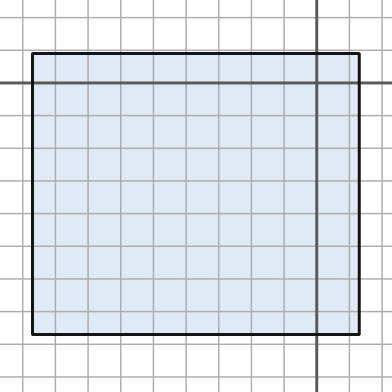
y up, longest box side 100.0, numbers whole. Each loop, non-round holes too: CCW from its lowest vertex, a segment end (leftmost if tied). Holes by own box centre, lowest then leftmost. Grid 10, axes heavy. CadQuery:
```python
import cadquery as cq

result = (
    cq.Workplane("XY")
    .moveTo(-87.0, -77.0)
    .lineTo(13.0, -77.0)
    .lineTo(13.0, 9.0)
    .lineTo(-87.0, 9.0)
    .close()
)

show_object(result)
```